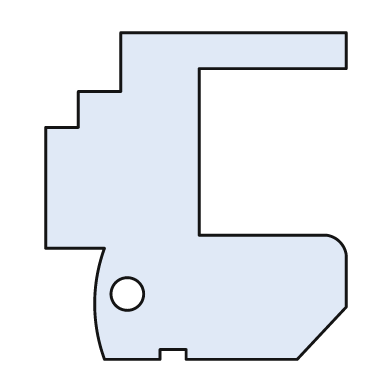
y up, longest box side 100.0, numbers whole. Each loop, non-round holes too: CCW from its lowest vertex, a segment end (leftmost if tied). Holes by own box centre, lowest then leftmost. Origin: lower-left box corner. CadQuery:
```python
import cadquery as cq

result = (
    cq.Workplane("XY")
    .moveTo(18.0, 0.0)
    .lineTo(35.0, 0.0)
    .lineTo(35.0, 3.0)
    .lineTo(43.0, 3.0)
    .lineTo(43.0, 0.0)
    .lineTo(77.0, 0.0)
    .lineTo(92.0, 16.0)
    .lineTo(92.0, 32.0)
    .threePointArc((90.0, 36.0), (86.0, 38.0))
    .lineTo(47.0, 38.0)
    .lineTo(47.0, 89.0)
    .lineTo(92.0, 89.0)
    .lineTo(92.0, 100.0)
    .lineTo(23.0, 100.0)
    .lineTo(23.0, 82.0)
    .lineTo(10.0, 82.0)
    .lineTo(10.0, 71.0)
    .lineTo(0.0, 71.0)
    .lineTo(0.0, 34.0)
    .lineTo(18.0, 34.0)
    .threePointArc((15.0, 17.0), (18.0, 0.0))
    .close()
    .moveTo(25.0, 20.0)
    .circle(5.0)
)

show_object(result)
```